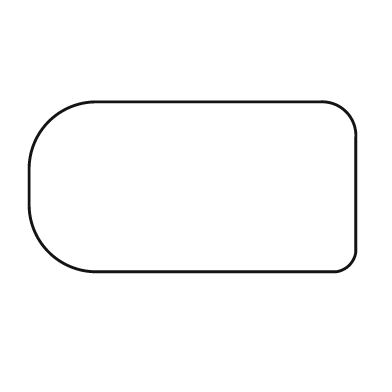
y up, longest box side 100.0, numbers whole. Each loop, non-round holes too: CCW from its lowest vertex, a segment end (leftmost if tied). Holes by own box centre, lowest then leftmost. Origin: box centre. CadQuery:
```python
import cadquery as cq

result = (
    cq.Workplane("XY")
    .moveTo(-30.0, -26.0)
    .lineTo(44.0, -26.0)
    .threePointArc((48.0, -24.0), (50.0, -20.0))
    .lineTo(50.0, 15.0)
    .threePointArc((47.0, 23.0), (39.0, 26.0))
    .lineTo(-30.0, 26.0)
    .threePointArc((-44.0, 20.0), (-50.0, 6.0))
    .lineTo(-50.0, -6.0)
    .threePointArc((-44.0, -20.0), (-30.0, -26.0))
    .close()
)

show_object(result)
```